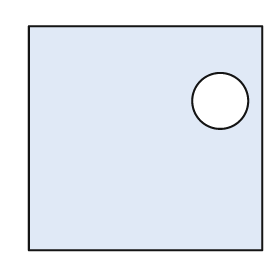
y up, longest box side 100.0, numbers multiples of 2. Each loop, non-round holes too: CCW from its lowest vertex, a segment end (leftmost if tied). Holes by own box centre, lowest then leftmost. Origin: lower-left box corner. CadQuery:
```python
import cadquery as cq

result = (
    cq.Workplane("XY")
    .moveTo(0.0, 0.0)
    .lineTo(100.0, 0.0)
    .lineTo(100.0, 96.0)
    .lineTo(0.0, 96.0)
    .close()
    .moveTo(82.0, 64.0)
    .circle(12.0)
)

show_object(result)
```